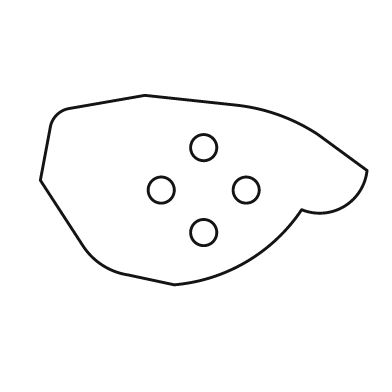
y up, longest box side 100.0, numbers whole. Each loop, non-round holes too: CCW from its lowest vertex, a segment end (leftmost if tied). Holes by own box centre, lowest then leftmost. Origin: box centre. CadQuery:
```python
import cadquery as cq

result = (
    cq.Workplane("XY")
    .moveTo(-9.0, -29.0)
    .threePointArc((13.0, -22.0), (30.0, -6.0))
    .threePointArc((43.0, -5.0), (50.0, 6.0))
    .lineTo(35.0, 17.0)
    .threePointArc((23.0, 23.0), (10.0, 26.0))
    .lineTo(-18.0, 29.0)
    .lineTo(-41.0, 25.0)
    .threePointArc((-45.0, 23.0), (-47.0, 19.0))
    .lineTo(-50.0, 3.0)
    .lineTo(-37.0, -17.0)
    .threePointArc((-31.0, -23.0), (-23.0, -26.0))
    .close()
    .moveTo(0.0, -13.0)
    .circle(4.0)
    .moveTo(-13.0, 0.0)
    .circle(4.0)
    .moveTo(13.0, 0.0)
    .circle(4.0)
    .moveTo(0.0, 13.0)
    .circle(4.0)
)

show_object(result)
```